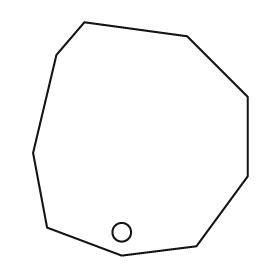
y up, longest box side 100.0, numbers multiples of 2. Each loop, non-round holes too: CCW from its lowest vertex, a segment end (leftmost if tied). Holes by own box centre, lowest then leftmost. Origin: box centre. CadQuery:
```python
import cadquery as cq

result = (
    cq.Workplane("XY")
    .moveTo(-8.0, -50.0)
    .lineTo(24.0, -46.0)
    .lineTo(46.0, -16.0)
    .lineTo(46.0, 18.0)
    .lineTo(20.0, 44.0)
    .lineTo(-24.0, 50.0)
    .lineTo(-36.0, 36.0)
    .lineTo(-46.0, -6.0)
    .lineTo(-40.0, -38.0)
    .close()
    .moveTo(-8.0, -40.0)
    .circle(4.0)
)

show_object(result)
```